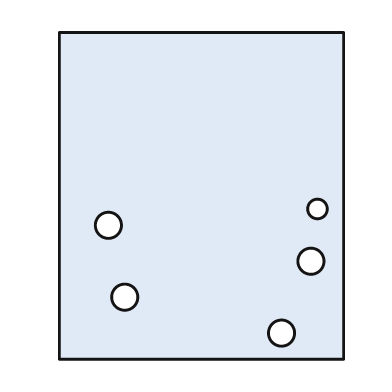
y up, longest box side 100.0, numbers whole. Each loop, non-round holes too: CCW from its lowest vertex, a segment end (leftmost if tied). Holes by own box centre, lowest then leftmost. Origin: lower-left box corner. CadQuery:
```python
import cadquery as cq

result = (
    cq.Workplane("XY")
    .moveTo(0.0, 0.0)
    .lineTo(87.0, 0.0)
    .lineTo(87.0, 100.0)
    .lineTo(0.0, 100.0)
    .close()
    .moveTo(68.0, 8.0)
    .circle(4.0)
    .moveTo(20.0, 19.0)
    .circle(4.0)
    .moveTo(77.0, 30.0)
    .circle(4.0)
    .moveTo(15.0, 41.0)
    .circle(4.0)
    .moveTo(79.0, 46.0)
    .circle(3.0)
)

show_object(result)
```